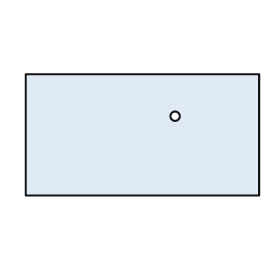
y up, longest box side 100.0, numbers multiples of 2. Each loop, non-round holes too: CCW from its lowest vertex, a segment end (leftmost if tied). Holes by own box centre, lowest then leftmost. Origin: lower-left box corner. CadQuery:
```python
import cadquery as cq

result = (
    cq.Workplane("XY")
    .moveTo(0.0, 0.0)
    .lineTo(100.0, 0.0)
    .lineTo(100.0, 52.0)
    .lineTo(0.0, 52.0)
    .close()
    .moveTo(64.0, 34.0)
    .circle(2.0)
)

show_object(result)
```